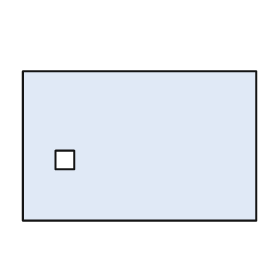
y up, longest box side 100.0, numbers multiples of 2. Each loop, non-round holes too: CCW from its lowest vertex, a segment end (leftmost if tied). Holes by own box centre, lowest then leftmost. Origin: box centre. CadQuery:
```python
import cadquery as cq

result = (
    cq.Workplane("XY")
    .moveTo(-50.0, -32.0)
    .lineTo(50.0, -32.0)
    .lineTo(50.0, 32.0)
    .lineTo(-50.0, 32.0)
    .close()
    .moveTo(-36.0, -10.0)
    .lineTo(-28.0, -10.0)
    .lineTo(-28.0, -2.0)
    .lineTo(-36.0, -2.0)
    .close()
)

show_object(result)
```